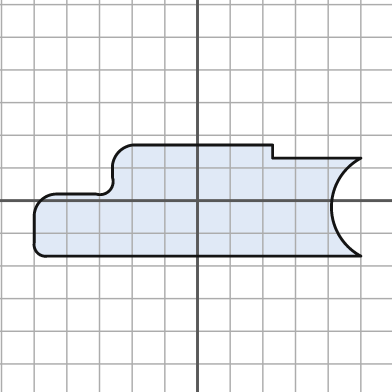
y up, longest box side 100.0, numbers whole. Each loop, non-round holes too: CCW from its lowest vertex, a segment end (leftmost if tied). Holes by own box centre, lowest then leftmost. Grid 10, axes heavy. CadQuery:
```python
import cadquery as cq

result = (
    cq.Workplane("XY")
    .moveTo(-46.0, -17.0)
    .lineTo(50.0, -17.0)
    .threePointArc((41.0, -2.0), (50.0, 13.0))
    .lineTo(23.0, 13.0)
    .lineTo(23.0, 17.0)
    .lineTo(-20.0, 17.0)
    .threePointArc((-24.0, 15.0), (-26.0, 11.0))
    .lineTo(-26.0, 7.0)
    .threePointArc((-27.0, 3.0), (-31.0, 2.0))
    .lineTo(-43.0, 2.0)
    .threePointArc((-48.0, 0.0), (-50.0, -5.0))
    .lineTo(-50.0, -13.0)
    .threePointArc((-49.0, -16.0), (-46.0, -17.0))
    .close()
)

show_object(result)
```